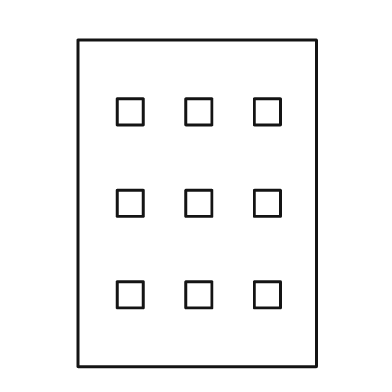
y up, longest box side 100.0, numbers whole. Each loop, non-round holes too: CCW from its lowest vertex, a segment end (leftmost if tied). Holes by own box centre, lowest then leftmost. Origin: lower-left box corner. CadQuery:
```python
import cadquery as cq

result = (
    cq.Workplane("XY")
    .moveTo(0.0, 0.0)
    .lineTo(73.0, 0.0)
    .lineTo(73.0, 100.0)
    .lineTo(0.0, 100.0)
    .close()
    .moveTo(12.0, 18.0)
    .lineTo(20.0, 18.0)
    .lineTo(20.0, 26.0)
    .lineTo(12.0, 26.0)
    .close()
    .moveTo(33.0, 18.0)
    .lineTo(41.0, 18.0)
    .lineTo(41.0, 26.0)
    .lineTo(33.0, 26.0)
    .close()
    .moveTo(54.0, 18.0)
    .lineTo(62.0, 18.0)
    .lineTo(62.0, 26.0)
    .lineTo(54.0, 26.0)
    .close()
    .moveTo(12.0, 46.0)
    .lineTo(20.0, 46.0)
    .lineTo(20.0, 54.0)
    .lineTo(12.0, 54.0)
    .close()
    .moveTo(33.0, 46.0)
    .lineTo(41.0, 46.0)
    .lineTo(41.0, 54.0)
    .lineTo(33.0, 54.0)
    .close()
    .moveTo(54.0, 46.0)
    .lineTo(62.0, 46.0)
    .lineTo(62.0, 54.0)
    .lineTo(54.0, 54.0)
    .close()
    .moveTo(12.0, 74.0)
    .lineTo(20.0, 74.0)
    .lineTo(20.0, 82.0)
    .lineTo(12.0, 82.0)
    .close()
    .moveTo(33.0, 74.0)
    .lineTo(41.0, 74.0)
    .lineTo(41.0, 82.0)
    .lineTo(33.0, 82.0)
    .close()
    .moveTo(54.0, 74.0)
    .lineTo(62.0, 74.0)
    .lineTo(62.0, 82.0)
    .lineTo(54.0, 82.0)
    .close()
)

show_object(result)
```